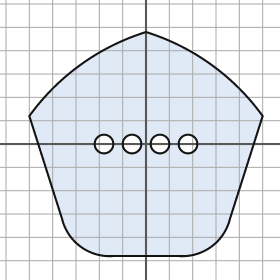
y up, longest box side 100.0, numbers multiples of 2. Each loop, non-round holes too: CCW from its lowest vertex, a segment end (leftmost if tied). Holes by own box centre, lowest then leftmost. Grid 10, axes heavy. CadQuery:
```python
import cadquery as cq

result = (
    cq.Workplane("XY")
    .moveTo(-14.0, -48.0)
    .lineTo(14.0, -48.0)
    .threePointArc((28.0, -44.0), (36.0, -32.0))
    .lineTo(50.0, 12.0)
    .threePointArc((28.0, 34.0), (0.0, 48.0))
    .threePointArc((-28.0, 34.0), (-50.0, 12.0))
    .lineTo(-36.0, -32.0)
    .threePointArc((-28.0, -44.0), (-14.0, -48.0))
    .close()
    .moveTo(-18.0, 0.0)
    .circle(4.0)
    .moveTo(-6.0, 0.0)
    .circle(4.0)
    .moveTo(6.0, 0.0)
    .circle(4.0)
    .moveTo(18.0, 0.0)
    .circle(4.0)
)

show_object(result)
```